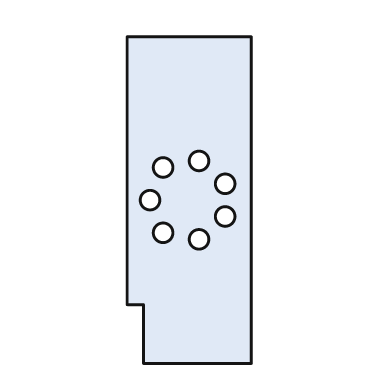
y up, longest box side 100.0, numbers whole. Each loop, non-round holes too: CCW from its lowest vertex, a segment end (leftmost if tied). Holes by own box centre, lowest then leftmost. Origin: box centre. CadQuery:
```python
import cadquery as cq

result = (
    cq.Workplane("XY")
    .moveTo(-14.0, -50.0)
    .lineTo(19.0, -50.0)
    .lineTo(19.0, 50.0)
    .lineTo(-19.0, 50.0)
    .lineTo(-19.0, -32.0)
    .lineTo(-14.0, -32.0)
    .close()
    .moveTo(3.0, -12.0)
    .circle(3.0)
    .moveTo(-8.0, -10.0)
    .circle(3.0)
    .moveTo(11.0, -5.0)
    .circle(3.0)
    .moveTo(-12.0, 0.0)
    .circle(3.0)
    .moveTo(11.0, 5.0)
    .circle(3.0)
    .moveTo(-8.0, 10.0)
    .circle(3.0)
    .moveTo(3.0, 12.0)
    .circle(3.0)
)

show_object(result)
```